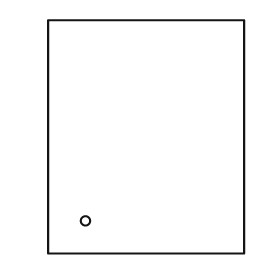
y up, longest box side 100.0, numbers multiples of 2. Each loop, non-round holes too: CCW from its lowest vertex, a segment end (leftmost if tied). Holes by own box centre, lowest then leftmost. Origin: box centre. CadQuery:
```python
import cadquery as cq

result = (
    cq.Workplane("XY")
    .moveTo(-42.0, -50.0)
    .lineTo(42.0, -50.0)
    .lineTo(42.0, 50.0)
    .lineTo(-42.0, 50.0)
    .close()
    .moveTo(-26.0, -36.0)
    .circle(2.0)
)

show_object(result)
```